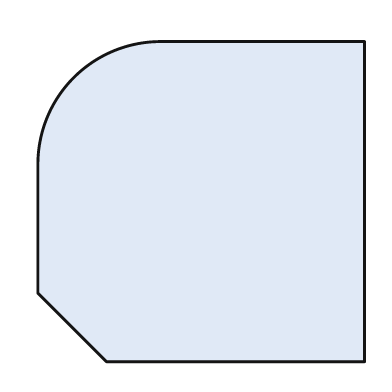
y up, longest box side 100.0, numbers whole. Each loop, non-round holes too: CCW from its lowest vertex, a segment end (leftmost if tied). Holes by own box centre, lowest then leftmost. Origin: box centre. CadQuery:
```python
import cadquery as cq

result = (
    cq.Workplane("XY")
    .moveTo(-29.0, -49.0)
    .lineTo(50.0, -49.0)
    .lineTo(50.0, 49.0)
    .lineTo(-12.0, 49.0)
    .threePointArc((-39.0, 38.0), (-50.0, 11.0))
    .lineTo(-50.0, -28.0)
    .close()
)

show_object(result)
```